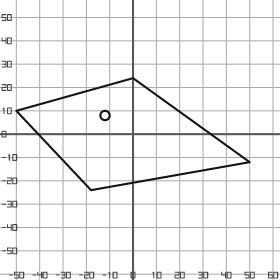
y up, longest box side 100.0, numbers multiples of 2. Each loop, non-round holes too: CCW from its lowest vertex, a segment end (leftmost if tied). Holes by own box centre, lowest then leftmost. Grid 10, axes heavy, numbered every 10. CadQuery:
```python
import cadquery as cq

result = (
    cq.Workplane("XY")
    .moveTo(-18.0, -24.0)
    .lineTo(50.0, -12.0)
    .lineTo(0.0, 24.0)
    .lineTo(-50.0, 10.0)
    .close()
    .moveTo(-12.0, 8.0)
    .circle(2.0)
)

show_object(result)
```